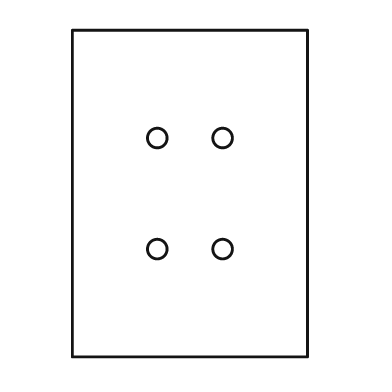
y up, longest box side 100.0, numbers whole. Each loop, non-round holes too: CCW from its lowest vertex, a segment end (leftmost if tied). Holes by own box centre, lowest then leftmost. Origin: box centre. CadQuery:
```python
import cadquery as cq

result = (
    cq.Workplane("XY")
    .moveTo(-36.0, -50.0)
    .lineTo(36.0, -50.0)
    .lineTo(36.0, 50.0)
    .lineTo(-36.0, 50.0)
    .close()
    .moveTo(-10.0, -17.0)
    .circle(3.0)
    .moveTo(10.0, -17.0)
    .circle(3.0)
    .moveTo(-10.0, 17.0)
    .circle(3.0)
    .moveTo(10.0, 17.0)
    .circle(3.0)
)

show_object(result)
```